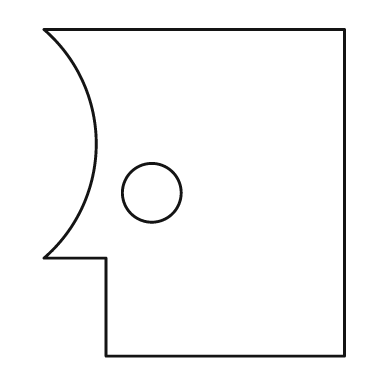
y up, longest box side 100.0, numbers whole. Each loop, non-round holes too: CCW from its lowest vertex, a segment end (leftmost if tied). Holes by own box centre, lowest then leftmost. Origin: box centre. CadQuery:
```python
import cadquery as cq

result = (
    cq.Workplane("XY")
    .moveTo(-27.0, -50.0)
    .lineTo(46.0, -50.0)
    .lineTo(46.0, 50.0)
    .lineTo(-46.0, 50.0)
    .threePointArc((-30.0, 15.0), (-46.0, -20.0))
    .lineTo(-27.0, -20.0)
    .close()
    .moveTo(-13.0, 0.0)
    .circle(9.0)
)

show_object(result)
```